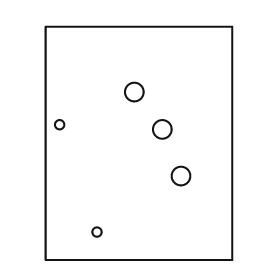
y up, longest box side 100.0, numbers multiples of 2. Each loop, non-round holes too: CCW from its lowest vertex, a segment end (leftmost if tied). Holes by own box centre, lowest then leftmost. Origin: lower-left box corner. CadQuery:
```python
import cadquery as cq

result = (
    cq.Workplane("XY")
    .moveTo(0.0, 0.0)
    .lineTo(80.0, 0.0)
    .lineTo(80.0, 100.0)
    .lineTo(0.0, 100.0)
    .close()
    .moveTo(22.0, 12.0)
    .circle(2.0)
    .moveTo(58.0, 36.0)
    .circle(4.0)
    .moveTo(50.0, 56.0)
    .circle(4.0)
    .moveTo(6.0, 58.0)
    .circle(2.0)
    .moveTo(38.0, 72.0)
    .circle(4.0)
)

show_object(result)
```